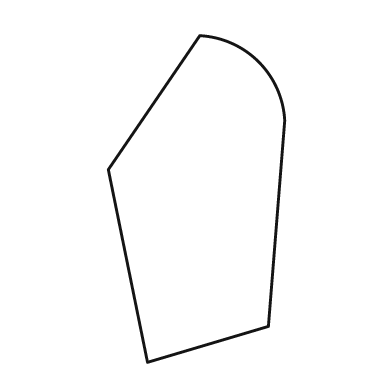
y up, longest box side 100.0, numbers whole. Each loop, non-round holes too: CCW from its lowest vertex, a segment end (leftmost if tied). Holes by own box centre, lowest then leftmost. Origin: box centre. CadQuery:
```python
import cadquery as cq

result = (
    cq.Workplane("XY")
    .moveTo(-15.0, -50.0)
    .lineTo(22.0, -39.0)
    .lineTo(27.0, 24.0)
    .threePointArc((19.0, 42.0), (1.0, 50.0))
    .lineTo(-27.0, 9.0)
    .close()
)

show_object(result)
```